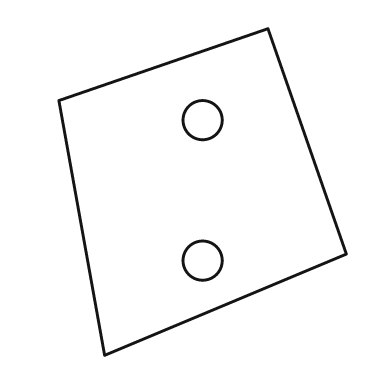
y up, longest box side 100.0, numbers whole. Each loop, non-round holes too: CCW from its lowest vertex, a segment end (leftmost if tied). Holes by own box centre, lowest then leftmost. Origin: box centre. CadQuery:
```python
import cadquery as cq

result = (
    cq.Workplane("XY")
    .moveTo(-30.0, -50.0)
    .lineTo(44.0, -19.0)
    .lineTo(20.0, 50.0)
    .lineTo(-44.0, 28.0)
    .close()
    .moveTo(0.0, -21.0)
    .circle(6.0)
    .moveTo(0.0, 22.0)
    .circle(6.0)
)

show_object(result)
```